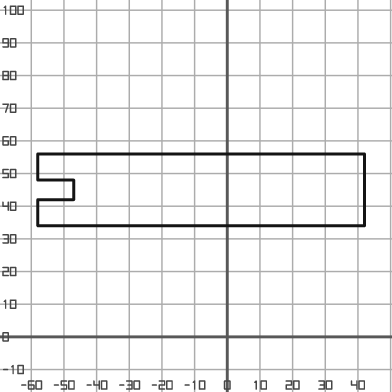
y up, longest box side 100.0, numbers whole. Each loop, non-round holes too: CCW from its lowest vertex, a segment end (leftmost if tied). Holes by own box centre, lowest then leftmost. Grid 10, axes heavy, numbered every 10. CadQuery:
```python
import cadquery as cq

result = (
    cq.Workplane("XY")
    .moveTo(-58.0, 34.0)
    .lineTo(42.0, 34.0)
    .lineTo(42.0, 56.0)
    .lineTo(-58.0, 56.0)
    .lineTo(-58.0, 48.0)
    .lineTo(-47.0, 48.0)
    .lineTo(-47.0, 42.0)
    .lineTo(-58.0, 42.0)
    .close()
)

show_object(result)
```